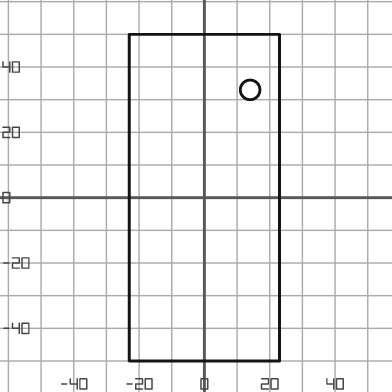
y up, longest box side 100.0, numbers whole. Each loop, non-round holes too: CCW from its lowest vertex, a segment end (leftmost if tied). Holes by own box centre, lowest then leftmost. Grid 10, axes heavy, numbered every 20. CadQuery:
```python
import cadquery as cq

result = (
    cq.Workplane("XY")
    .moveTo(-23.0, -50.0)
    .lineTo(23.0, -50.0)
    .lineTo(23.0, 50.0)
    .lineTo(-23.0, 50.0)
    .close()
    .moveTo(14.0, 33.0)
    .circle(3.0)
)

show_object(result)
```